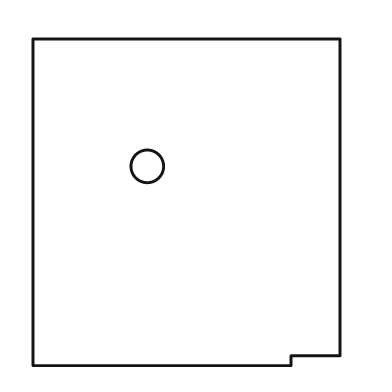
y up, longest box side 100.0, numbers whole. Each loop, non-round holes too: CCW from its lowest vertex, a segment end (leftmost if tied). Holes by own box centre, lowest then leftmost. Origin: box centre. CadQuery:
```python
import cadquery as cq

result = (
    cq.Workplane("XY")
    .moveTo(-47.0, -50.0)
    .lineTo(32.0, -50.0)
    .lineTo(32.0, -47.0)
    .lineTo(47.0, -47.0)
    .lineTo(47.0, 50.0)
    .lineTo(-47.0, 50.0)
    .close()
    .moveTo(-12.0, 11.0)
    .circle(5.0)
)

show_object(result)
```